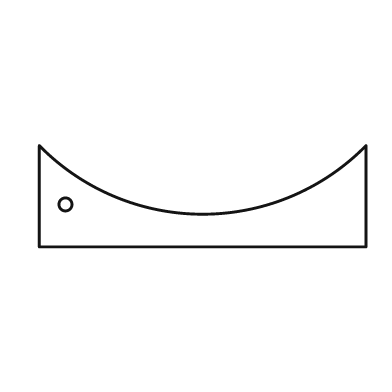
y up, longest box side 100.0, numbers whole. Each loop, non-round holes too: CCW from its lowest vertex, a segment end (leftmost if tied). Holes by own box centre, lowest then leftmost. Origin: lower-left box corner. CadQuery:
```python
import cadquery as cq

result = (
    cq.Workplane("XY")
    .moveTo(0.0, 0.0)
    .lineTo(100.0, 0.0)
    .lineTo(100.0, 31.0)
    .threePointArc((50.0, 10.0), (0.0, 31.0))
    .close()
    .moveTo(8.0, 13.0)
    .circle(2.0)
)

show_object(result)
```